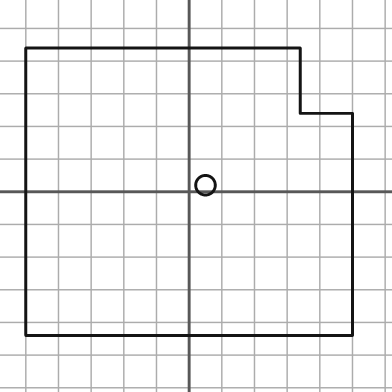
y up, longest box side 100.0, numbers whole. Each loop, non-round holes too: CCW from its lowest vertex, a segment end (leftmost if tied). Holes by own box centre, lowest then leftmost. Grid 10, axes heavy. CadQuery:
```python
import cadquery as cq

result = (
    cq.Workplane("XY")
    .moveTo(-50.0, -44.0)
    .lineTo(50.0, -44.0)
    .lineTo(50.0, 24.0)
    .lineTo(34.0, 24.0)
    .lineTo(34.0, 44.0)
    .lineTo(-50.0, 44.0)
    .close()
    .moveTo(5.0, 2.0)
    .circle(3.0)
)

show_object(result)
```